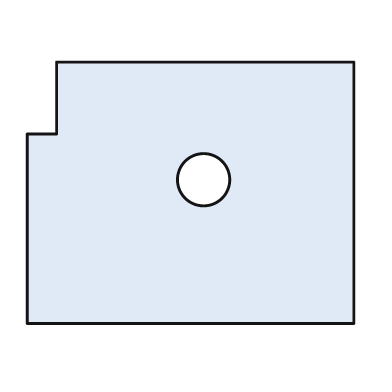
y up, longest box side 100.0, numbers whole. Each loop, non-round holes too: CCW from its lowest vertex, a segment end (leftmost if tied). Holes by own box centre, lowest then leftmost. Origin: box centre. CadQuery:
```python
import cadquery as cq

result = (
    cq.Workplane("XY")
    .moveTo(-50.0, -40.0)
    .lineTo(50.0, -40.0)
    .lineTo(50.0, 40.0)
    .lineTo(-41.0, 40.0)
    .lineTo(-41.0, 18.0)
    .lineTo(-50.0, 18.0)
    .close()
    .moveTo(4.0, 4.0)
    .circle(8.0)
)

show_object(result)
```